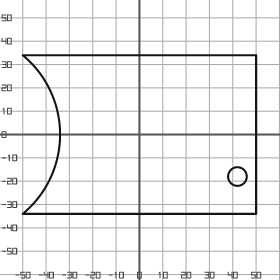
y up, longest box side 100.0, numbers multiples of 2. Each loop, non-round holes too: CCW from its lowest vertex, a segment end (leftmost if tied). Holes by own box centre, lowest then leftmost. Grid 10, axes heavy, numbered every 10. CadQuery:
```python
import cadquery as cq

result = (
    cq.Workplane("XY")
    .moveTo(-50.0, -34.0)
    .lineTo(50.0, -34.0)
    .lineTo(50.0, 34.0)
    .lineTo(-50.0, 34.0)
    .threePointArc((-34.0, 0.0), (-50.0, -34.0))
    .close()
    .moveTo(42.0, -18.0)
    .circle(4.0)
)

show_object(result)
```